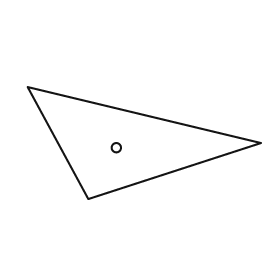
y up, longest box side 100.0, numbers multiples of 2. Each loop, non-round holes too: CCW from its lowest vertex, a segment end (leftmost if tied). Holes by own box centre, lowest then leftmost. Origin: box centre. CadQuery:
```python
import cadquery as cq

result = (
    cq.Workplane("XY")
    .moveTo(-24.0, -24.0)
    .lineTo(50.0, 0.0)
    .lineTo(-50.0, 24.0)
    .close()
    .moveTo(-12.0, -2.0)
    .circle(2.0)
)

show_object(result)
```